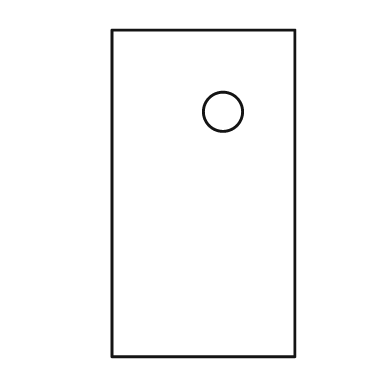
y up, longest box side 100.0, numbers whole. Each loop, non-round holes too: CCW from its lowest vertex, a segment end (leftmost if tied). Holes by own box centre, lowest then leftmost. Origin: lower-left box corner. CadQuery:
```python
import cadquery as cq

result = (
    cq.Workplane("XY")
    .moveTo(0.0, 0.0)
    .lineTo(56.0, 0.0)
    .lineTo(56.0, 100.0)
    .lineTo(0.0, 100.0)
    .close()
    .moveTo(34.0, 75.0)
    .circle(6.0)
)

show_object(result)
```